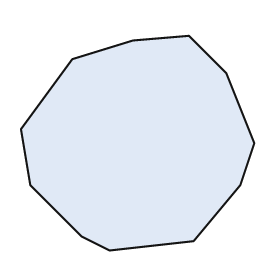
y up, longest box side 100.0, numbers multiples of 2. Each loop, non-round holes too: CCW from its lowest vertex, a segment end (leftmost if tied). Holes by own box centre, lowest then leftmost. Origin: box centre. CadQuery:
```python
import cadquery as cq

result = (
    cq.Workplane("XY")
    .moveTo(-12.0, -46.0)
    .lineTo(24.0, -42.0)
    .lineTo(44.0, -18.0)
    .lineTo(50.0, 0.0)
    .lineTo(38.0, 30.0)
    .lineTo(22.0, 46.0)
    .lineTo(-2.0, 44.0)
    .lineTo(-28.0, 36.0)
    .lineTo(-50.0, 6.0)
    .lineTo(-46.0, -18.0)
    .lineTo(-24.0, -40.0)
    .close()
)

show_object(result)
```